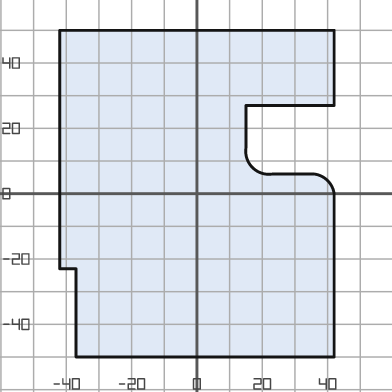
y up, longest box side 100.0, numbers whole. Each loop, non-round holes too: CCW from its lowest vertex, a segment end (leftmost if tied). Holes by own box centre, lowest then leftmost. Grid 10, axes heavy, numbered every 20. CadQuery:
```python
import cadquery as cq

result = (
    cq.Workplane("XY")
    .moveTo(-37.0, -50.0)
    .lineTo(42.0, -50.0)
    .lineTo(42.0, 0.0)
    .threePointArc((40.0, 4.0), (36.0, 6.0))
    .lineTo(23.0, 6.0)
    .threePointArc((17.0, 8.0), (15.0, 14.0))
    .lineTo(15.0, 27.0)
    .lineTo(42.0, 27.0)
    .lineTo(42.0, 50.0)
    .lineTo(-42.0, 50.0)
    .lineTo(-42.0, -23.0)
    .lineTo(-37.0, -23.0)
    .close()
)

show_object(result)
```